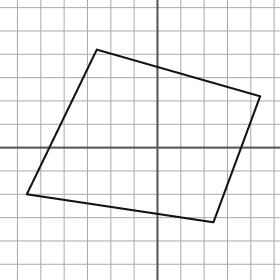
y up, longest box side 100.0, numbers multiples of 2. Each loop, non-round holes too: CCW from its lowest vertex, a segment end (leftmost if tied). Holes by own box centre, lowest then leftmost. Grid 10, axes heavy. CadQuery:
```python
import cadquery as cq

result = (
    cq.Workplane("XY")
    .moveTo(24.0, -32.0)
    .lineTo(44.0, 22.0)
    .lineTo(-26.0, 42.0)
    .lineTo(-56.0, -20.0)
    .close()
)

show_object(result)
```